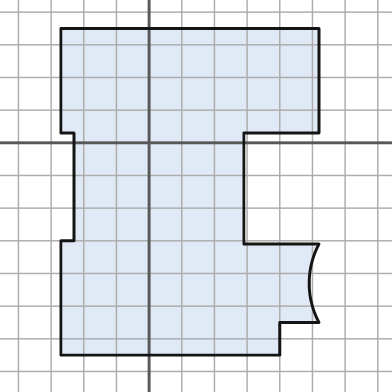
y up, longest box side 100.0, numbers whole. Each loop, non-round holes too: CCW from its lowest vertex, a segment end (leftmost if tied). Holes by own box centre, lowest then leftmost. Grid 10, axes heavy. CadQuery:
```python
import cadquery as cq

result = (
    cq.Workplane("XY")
    .moveTo(-27.0, -65.0)
    .lineTo(40.0, -65.0)
    .lineTo(40.0, -55.0)
    .lineTo(52.0, -55.0)
    .threePointArc((49.0, -43.0), (52.0, -31.0))
    .lineTo(29.0, -31.0)
    .lineTo(29.0, 3.0)
    .lineTo(52.0, 3.0)
    .lineTo(52.0, 35.0)
    .lineTo(-27.0, 35.0)
    .lineTo(-27.0, 3.0)
    .lineTo(-23.0, 3.0)
    .lineTo(-23.0, -30.0)
    .lineTo(-27.0, -30.0)
    .close()
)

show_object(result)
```